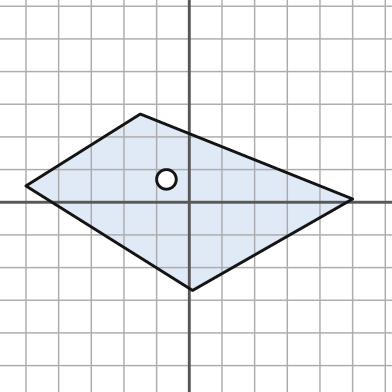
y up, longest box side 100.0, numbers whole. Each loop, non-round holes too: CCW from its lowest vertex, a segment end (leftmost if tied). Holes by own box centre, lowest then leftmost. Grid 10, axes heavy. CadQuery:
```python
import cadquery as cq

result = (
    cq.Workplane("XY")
    .moveTo(1.0, -27.0)
    .lineTo(50.0, 1.0)
    .lineTo(-15.0, 27.0)
    .lineTo(-50.0, 5.0)
    .close()
    .moveTo(-7.0, 7.0)
    .circle(3.0)
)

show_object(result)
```